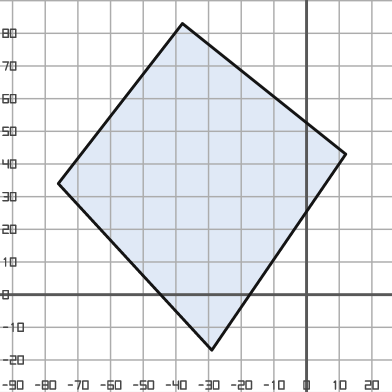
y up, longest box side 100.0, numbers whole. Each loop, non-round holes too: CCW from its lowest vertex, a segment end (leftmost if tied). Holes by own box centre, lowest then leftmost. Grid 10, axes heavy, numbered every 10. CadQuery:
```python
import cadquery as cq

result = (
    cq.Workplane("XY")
    .moveTo(-29.0, -17.0)
    .lineTo(12.0, 43.0)
    .lineTo(-38.0, 83.0)
    .lineTo(-76.0, 34.0)
    .close()
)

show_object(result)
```